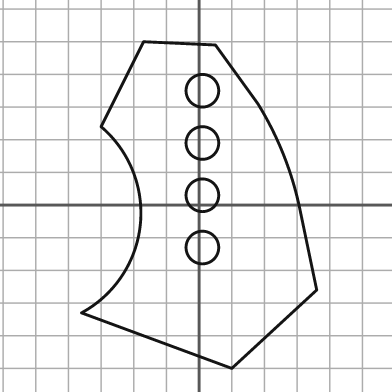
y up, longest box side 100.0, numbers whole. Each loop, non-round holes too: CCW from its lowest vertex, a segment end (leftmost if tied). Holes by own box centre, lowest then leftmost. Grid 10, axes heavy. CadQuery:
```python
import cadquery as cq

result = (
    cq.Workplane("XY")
    .moveTo(10.0, -50.0)
    .lineTo(36.0, -26.0)
    .lineTo(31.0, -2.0)
    .threePointArc((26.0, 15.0), (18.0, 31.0))
    .lineTo(5.0, 49.0)
    .lineTo(-17.0, 50.0)
    .lineTo(-30.0, 24.0)
    .threePointArc((-18.0, -6.0), (-36.0, -33.0))
    .close()
    .moveTo(1.0, -13.0)
    .circle(5.0)
    .moveTo(1.0, 3.0)
    .circle(5.0)
    .moveTo(1.0, 19.0)
    .circle(5.0)
    .moveTo(1.0, 35.0)
    .circle(5.0)
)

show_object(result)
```